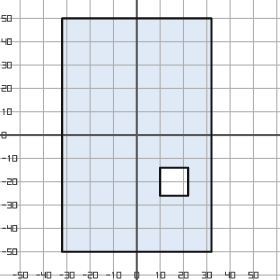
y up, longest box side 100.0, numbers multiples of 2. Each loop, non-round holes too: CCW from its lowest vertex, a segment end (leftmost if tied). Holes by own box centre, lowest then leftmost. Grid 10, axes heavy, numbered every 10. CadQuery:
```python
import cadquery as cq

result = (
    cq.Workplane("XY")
    .moveTo(-32.0, -50.0)
    .lineTo(32.0, -50.0)
    .lineTo(32.0, 50.0)
    .lineTo(-32.0, 50.0)
    .close()
    .moveTo(10.0, -26.0)
    .lineTo(22.0, -26.0)
    .lineTo(22.0, -14.0)
    .lineTo(10.0, -14.0)
    .close()
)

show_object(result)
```